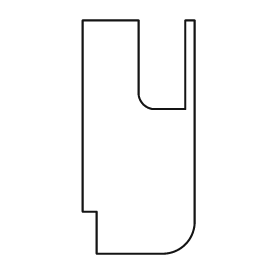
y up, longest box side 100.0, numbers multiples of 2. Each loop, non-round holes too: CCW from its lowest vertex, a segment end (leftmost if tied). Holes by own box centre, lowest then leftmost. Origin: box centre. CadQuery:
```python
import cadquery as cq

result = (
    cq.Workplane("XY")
    .moveTo(-18.0, -50.0)
    .lineTo(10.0, -50.0)
    .threePointArc((20.0, -46.0), (24.0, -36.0))
    .lineTo(24.0, 50.0)
    .lineTo(20.0, 50.0)
    .lineTo(20.0, 12.0)
    .lineTo(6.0, 12.0)
    .threePointArc((2.0, 14.0), (0.0, 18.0))
    .lineTo(0.0, 50.0)
    .lineTo(-24.0, 50.0)
    .lineTo(-24.0, -32.0)
    .lineTo(-18.0, -32.0)
    .close()
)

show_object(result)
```